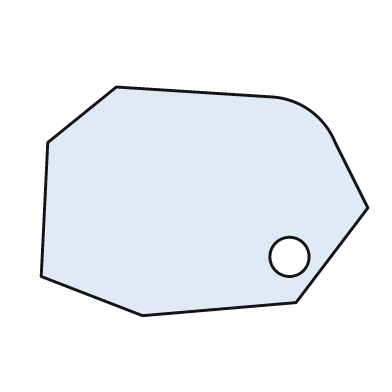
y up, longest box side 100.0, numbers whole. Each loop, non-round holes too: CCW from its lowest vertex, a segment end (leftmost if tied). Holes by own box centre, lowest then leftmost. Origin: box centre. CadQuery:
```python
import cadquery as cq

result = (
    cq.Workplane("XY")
    .moveTo(-19.0, -35.0)
    .lineTo(28.0, -31.0)
    .lineTo(50.0, -2.0)
    .lineTo(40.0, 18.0)
    .threePointArc((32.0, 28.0), (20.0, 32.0))
    .lineTo(-27.0, 35.0)
    .lineTo(-48.0, 18.0)
    .lineTo(-50.0, -23.0)
    .close()
    .moveTo(26.0, -17.0)
    .circle(6.0)
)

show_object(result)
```